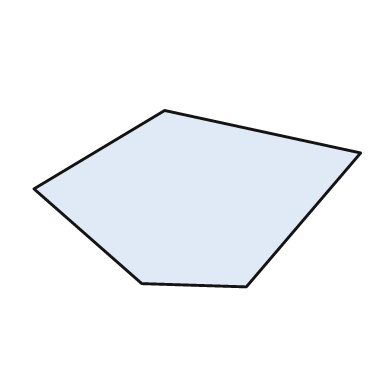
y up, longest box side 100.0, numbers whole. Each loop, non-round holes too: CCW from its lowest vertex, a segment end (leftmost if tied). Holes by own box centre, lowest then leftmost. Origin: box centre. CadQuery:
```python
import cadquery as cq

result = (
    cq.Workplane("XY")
    .moveTo(15.0, -27.0)
    .lineTo(50.0, 14.0)
    .lineTo(-10.0, 27.0)
    .lineTo(-50.0, 3.0)
    .lineTo(-17.0, -26.0)
    .close()
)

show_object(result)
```